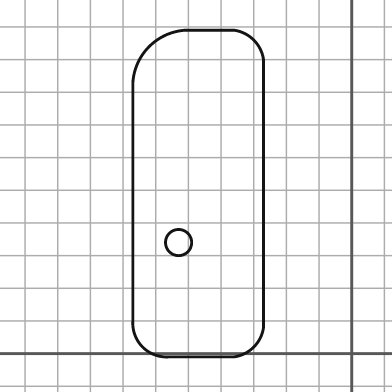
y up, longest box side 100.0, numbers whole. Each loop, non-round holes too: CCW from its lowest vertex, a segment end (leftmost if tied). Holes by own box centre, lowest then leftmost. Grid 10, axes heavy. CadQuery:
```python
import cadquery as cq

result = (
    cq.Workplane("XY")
    .moveTo(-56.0, -1.0)
    .lineTo(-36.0, -1.0)
    .threePointArc((-30.0, 2.0), (-27.0, 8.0))
    .lineTo(-27.0, 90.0)
    .threePointArc((-30.0, 96.0), (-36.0, 99.0))
    .lineTo(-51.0, 99.0)
    .threePointArc((-62.0, 94.0), (-67.0, 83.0))
    .lineTo(-67.0, 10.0)
    .threePointArc((-64.0, 2.0), (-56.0, -1.0))
    .close()
    .moveTo(-53.0, 34.0)
    .circle(4.0)
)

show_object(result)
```